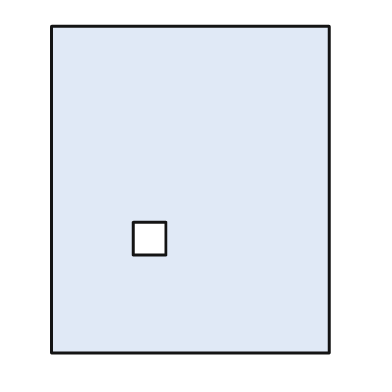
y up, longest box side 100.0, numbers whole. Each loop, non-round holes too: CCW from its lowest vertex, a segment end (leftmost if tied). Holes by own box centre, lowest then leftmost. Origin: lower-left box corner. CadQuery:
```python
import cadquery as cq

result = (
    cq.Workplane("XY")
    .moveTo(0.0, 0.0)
    .lineTo(85.0, 0.0)
    .lineTo(85.0, 100.0)
    .lineTo(0.0, 100.0)
    .close()
    .moveTo(25.0, 30.0)
    .lineTo(35.0, 30.0)
    .lineTo(35.0, 40.0)
    .lineTo(25.0, 40.0)
    .close()
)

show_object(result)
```